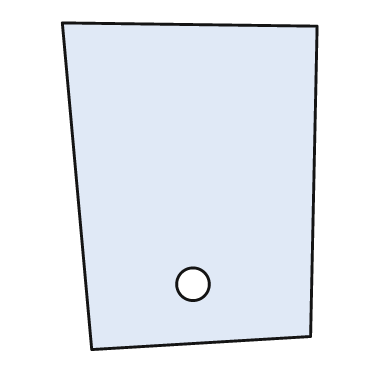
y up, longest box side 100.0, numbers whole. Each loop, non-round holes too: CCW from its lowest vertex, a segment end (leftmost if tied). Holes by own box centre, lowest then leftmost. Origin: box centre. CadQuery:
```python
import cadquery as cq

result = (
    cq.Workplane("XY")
    .moveTo(-30.0, -50.0)
    .lineTo(37.0, -46.0)
    .lineTo(39.0, 49.0)
    .lineTo(-39.0, 50.0)
    .close()
    .moveTo(1.0, -30.0)
    .circle(5.0)
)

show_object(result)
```